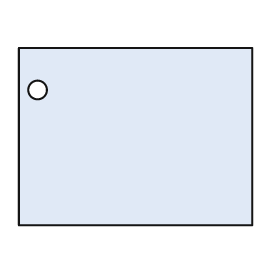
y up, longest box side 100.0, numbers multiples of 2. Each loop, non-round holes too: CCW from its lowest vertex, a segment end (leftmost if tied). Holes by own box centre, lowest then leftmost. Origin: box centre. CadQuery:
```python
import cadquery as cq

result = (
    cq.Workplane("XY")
    .moveTo(-50.0, -38.0)
    .lineTo(50.0, -38.0)
    .lineTo(50.0, 38.0)
    .lineTo(-50.0, 38.0)
    .close()
    .moveTo(-42.0, 20.0)
    .circle(4.0)
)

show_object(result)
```